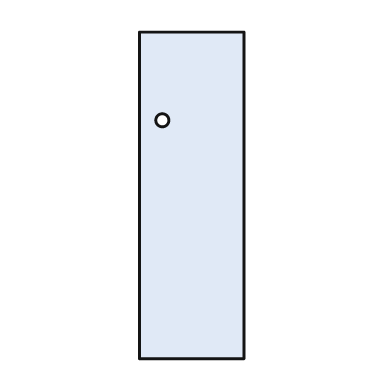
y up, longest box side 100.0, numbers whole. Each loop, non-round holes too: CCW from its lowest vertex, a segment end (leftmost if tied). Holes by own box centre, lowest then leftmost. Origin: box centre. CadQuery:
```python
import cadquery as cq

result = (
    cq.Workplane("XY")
    .moveTo(-16.0, -50.0)
    .lineTo(16.0, -50.0)
    .lineTo(16.0, 50.0)
    .lineTo(-16.0, 50.0)
    .close()
    .moveTo(-9.0, 23.0)
    .circle(2.0)
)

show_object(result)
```